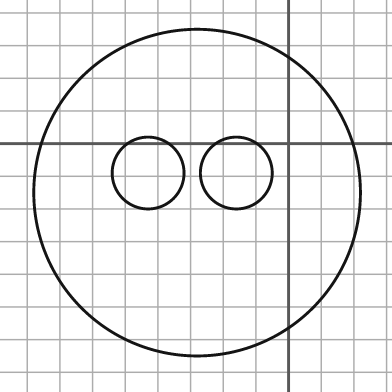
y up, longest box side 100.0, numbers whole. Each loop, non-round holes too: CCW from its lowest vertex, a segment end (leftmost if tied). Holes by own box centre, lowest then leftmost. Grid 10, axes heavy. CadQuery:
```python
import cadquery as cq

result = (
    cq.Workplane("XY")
    .moveTo(-28.0, -15.0)
    .circle(50.0)
    .moveTo(-43.0, -9.0)
    .circle(11.0)
    .moveTo(-16.0, -9.0)
    .circle(11.0)
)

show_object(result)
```